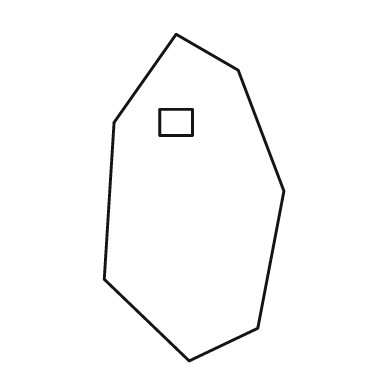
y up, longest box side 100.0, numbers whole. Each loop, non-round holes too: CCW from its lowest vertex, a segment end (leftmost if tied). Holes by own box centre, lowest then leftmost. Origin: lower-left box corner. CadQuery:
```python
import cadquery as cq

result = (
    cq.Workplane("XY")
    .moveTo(26.0, 0.0)
    .lineTo(47.0, 10.0)
    .lineTo(55.0, 52.0)
    .lineTo(41.0, 89.0)
    .lineTo(22.0, 100.0)
    .lineTo(3.0, 73.0)
    .lineTo(0.0, 25.0)
    .close()
    .moveTo(17.0, 69.0)
    .lineTo(27.0, 69.0)
    .lineTo(27.0, 77.0)
    .lineTo(17.0, 77.0)
    .close()
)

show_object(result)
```